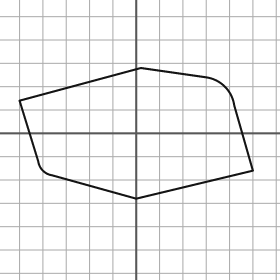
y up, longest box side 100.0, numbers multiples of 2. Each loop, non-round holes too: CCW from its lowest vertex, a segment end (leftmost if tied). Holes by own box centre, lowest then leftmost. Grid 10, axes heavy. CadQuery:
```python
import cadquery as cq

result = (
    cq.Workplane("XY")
    .moveTo(0.0, -28.0)
    .lineTo(50.0, -16.0)
    .lineTo(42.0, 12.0)
    .threePointArc((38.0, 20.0), (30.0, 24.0))
    .lineTo(2.0, 28.0)
    .lineTo(-50.0, 14.0)
    .lineTo(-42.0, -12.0)
    .threePointArc((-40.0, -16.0), (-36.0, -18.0))
    .close()
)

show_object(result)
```